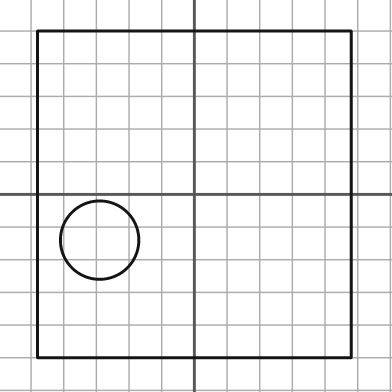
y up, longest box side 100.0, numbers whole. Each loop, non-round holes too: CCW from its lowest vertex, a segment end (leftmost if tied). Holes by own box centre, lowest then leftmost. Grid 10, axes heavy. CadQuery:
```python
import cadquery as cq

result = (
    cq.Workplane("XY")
    .moveTo(-48.0, -50.0)
    .lineTo(48.0, -50.0)
    .lineTo(48.0, 50.0)
    .lineTo(-48.0, 50.0)
    .close()
    .moveTo(-29.0, -14.0)
    .circle(12.0)
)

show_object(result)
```